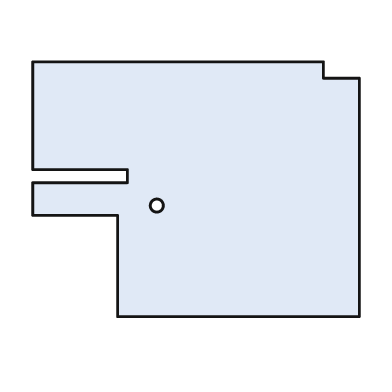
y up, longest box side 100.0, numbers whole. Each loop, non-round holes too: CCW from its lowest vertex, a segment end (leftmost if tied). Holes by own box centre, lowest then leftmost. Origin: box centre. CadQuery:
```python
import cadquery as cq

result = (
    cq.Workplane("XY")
    .moveTo(-24.0, -39.0)
    .lineTo(50.0, -39.0)
    .lineTo(50.0, 34.0)
    .lineTo(39.0, 34.0)
    .lineTo(39.0, 39.0)
    .lineTo(-50.0, 39.0)
    .lineTo(-50.0, 6.0)
    .lineTo(-21.0, 6.0)
    .lineTo(-21.0, 2.0)
    .lineTo(-50.0, 2.0)
    .lineTo(-50.0, -8.0)
    .lineTo(-24.0, -8.0)
    .close()
    .moveTo(-12.0, -5.0)
    .circle(2.0)
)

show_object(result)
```